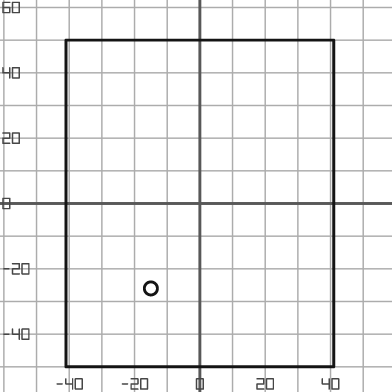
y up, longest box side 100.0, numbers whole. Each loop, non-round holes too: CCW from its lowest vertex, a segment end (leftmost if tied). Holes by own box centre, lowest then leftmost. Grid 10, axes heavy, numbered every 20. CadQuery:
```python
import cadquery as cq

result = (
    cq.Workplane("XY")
    .moveTo(-41.0, -50.0)
    .lineTo(41.0, -50.0)
    .lineTo(41.0, 50.0)
    .lineTo(-41.0, 50.0)
    .close()
    .moveTo(-15.0, -26.0)
    .circle(2.0)
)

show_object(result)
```